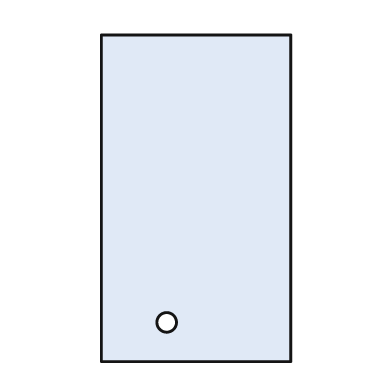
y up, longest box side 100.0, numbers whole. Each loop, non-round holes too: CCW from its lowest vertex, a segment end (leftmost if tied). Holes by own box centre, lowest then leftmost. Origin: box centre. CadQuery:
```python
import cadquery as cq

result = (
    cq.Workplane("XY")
    .moveTo(-29.0, -50.0)
    .lineTo(29.0, -50.0)
    .lineTo(29.0, 50.0)
    .lineTo(-29.0, 50.0)
    .close()
    .moveTo(-9.0, -38.0)
    .circle(3.0)
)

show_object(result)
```